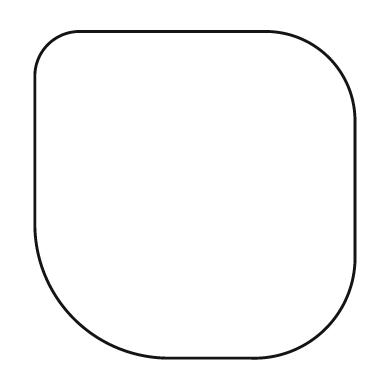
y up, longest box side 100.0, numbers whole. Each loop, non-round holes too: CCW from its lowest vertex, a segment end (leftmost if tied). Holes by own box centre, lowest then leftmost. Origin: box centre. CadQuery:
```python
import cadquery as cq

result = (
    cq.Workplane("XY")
    .moveTo(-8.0, -50.0)
    .lineTo(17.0, -50.0)
    .threePointArc((40.0, -41.0), (49.0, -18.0))
    .lineTo(49.0, 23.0)
    .threePointArc((41.0, 42.0), (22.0, 50.0))
    .lineTo(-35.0, 50.0)
    .threePointArc((-45.0, 46.0), (-49.0, 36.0))
    .lineTo(-49.0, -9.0)
    .threePointArc((-37.0, -38.0), (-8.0, -50.0))
    .close()
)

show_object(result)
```